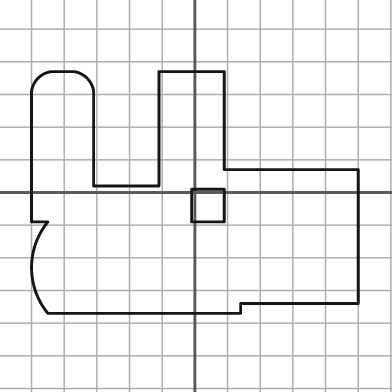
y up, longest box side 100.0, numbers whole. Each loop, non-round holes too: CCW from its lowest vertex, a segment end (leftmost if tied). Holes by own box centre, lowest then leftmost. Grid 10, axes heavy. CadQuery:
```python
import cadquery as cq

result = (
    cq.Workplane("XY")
    .moveTo(-45.0, -37.0)
    .lineTo(14.0, -37.0)
    .lineTo(14.0, -34.0)
    .lineTo(50.0, -34.0)
    .lineTo(50.0, 7.0)
    .lineTo(9.0, 7.0)
    .lineTo(9.0, 37.0)
    .lineTo(-11.0, 37.0)
    .lineTo(-11.0, 2.0)
    .lineTo(-31.0, 2.0)
    .lineTo(-31.0, 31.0)
    .threePointArc((-33.0, 35.0), (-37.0, 37.0))
    .lineTo(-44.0, 37.0)
    .threePointArc((-48.0, 35.0), (-50.0, 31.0))
    .lineTo(-50.0, -9.0)
    .lineTo(-45.0, -9.0)
    .threePointArc((-50.0, -23.0), (-45.0, -37.0))
    .close()
    .moveTo(-1.0, -9.0)
    .lineTo(9.0, -9.0)
    .lineTo(9.0, 1.0)
    .lineTo(-1.0, 1.0)
    .close()
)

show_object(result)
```